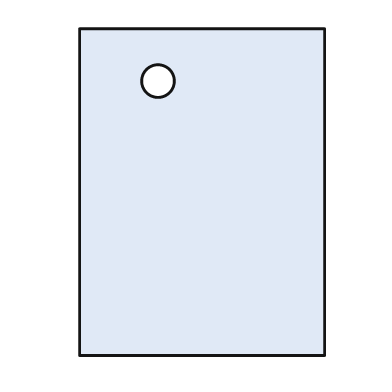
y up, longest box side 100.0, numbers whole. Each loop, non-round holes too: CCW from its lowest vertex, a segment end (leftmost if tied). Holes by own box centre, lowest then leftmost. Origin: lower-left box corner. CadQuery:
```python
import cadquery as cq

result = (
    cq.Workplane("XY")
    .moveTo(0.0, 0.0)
    .lineTo(75.0, 0.0)
    .lineTo(75.0, 100.0)
    .lineTo(0.0, 100.0)
    .close()
    .moveTo(24.0, 84.0)
    .circle(5.0)
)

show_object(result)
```